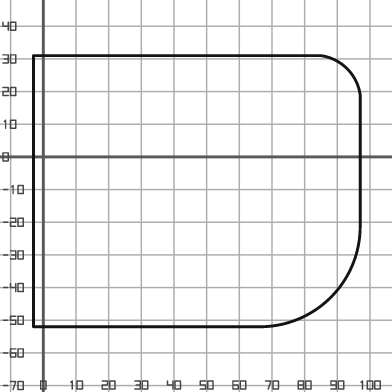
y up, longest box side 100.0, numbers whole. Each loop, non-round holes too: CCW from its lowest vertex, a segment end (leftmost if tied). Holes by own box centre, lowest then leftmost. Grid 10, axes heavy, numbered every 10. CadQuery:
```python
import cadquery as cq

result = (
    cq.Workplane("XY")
    .moveTo(-3.0, -52.0)
    .lineTo(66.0, -52.0)
    .threePointArc((88.0, -43.0), (97.0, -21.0))
    .lineTo(97.0, 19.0)
    .threePointArc((93.0, 27.0), (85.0, 31.0))
    .lineTo(-3.0, 31.0)
    .close()
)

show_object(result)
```